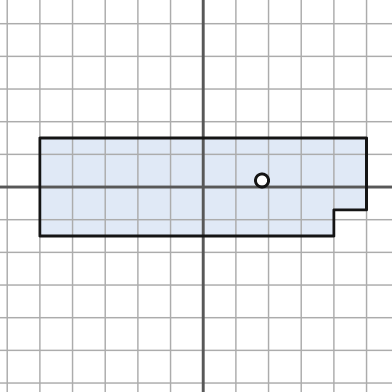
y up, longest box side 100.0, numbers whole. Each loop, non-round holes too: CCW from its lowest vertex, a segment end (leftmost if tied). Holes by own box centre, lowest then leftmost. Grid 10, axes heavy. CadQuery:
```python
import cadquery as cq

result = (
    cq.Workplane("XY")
    .moveTo(-50.0, -15.0)
    .lineTo(40.0, -15.0)
    .lineTo(40.0, -7.0)
    .lineTo(50.0, -7.0)
    .lineTo(50.0, 15.0)
    .lineTo(-50.0, 15.0)
    .close()
    .moveTo(18.0, 2.0)
    .circle(2.0)
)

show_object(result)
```